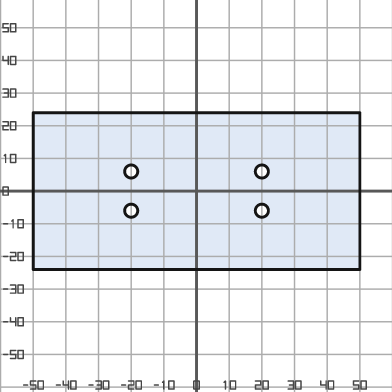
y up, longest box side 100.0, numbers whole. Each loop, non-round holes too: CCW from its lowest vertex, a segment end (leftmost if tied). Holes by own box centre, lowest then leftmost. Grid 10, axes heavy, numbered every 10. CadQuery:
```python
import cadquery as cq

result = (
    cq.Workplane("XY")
    .moveTo(-50.0, -24.0)
    .lineTo(50.0, -24.0)
    .lineTo(50.0, 24.0)
    .lineTo(-50.0, 24.0)
    .close()
    .moveTo(-20.0, -6.0)
    .circle(2.0)
    .moveTo(20.0, -6.0)
    .circle(2.0)
    .moveTo(-20.0, 6.0)
    .circle(2.0)
    .moveTo(20.0, 6.0)
    .circle(2.0)
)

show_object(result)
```